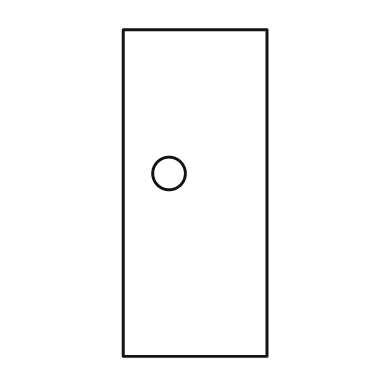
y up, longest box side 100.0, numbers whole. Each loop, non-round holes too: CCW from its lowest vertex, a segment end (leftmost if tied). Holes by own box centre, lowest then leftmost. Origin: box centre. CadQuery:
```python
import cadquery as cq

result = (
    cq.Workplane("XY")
    .moveTo(-22.0, -50.0)
    .lineTo(22.0, -50.0)
    .lineTo(22.0, 50.0)
    .lineTo(-22.0, 50.0)
    .close()
    .moveTo(-8.0, 6.0)
    .circle(5.0)
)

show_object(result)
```